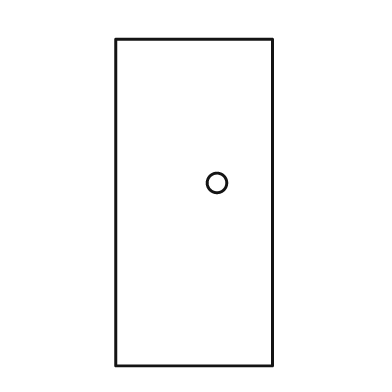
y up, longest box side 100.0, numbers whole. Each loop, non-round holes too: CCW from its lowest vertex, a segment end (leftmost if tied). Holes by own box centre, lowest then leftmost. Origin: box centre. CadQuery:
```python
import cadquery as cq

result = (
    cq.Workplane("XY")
    .moveTo(-24.0, -50.0)
    .lineTo(24.0, -50.0)
    .lineTo(24.0, 50.0)
    .lineTo(-24.0, 50.0)
    .close()
    .moveTo(7.0, 6.0)
    .circle(3.0)
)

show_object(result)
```